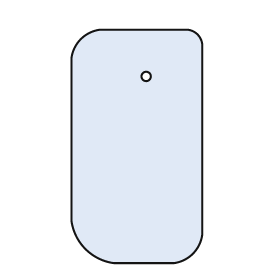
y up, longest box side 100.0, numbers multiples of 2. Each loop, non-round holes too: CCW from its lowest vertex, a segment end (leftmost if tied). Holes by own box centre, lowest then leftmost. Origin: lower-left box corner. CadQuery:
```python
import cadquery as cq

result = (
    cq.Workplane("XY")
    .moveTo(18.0, 0.0)
    .lineTo(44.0, 0.0)
    .threePointArc((52.0, 4.0), (56.0, 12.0))
    .lineTo(56.0, 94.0)
    .threePointArc((54.0, 98.0), (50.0, 100.0))
    .lineTo(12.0, 100.0)
    .threePointArc((4.0, 96.0), (0.0, 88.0))
    .lineTo(0.0, 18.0)
    .threePointArc((6.0, 6.0), (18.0, 0.0))
    .close()
    .moveTo(32.0, 80.0)
    .circle(2.0)
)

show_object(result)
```